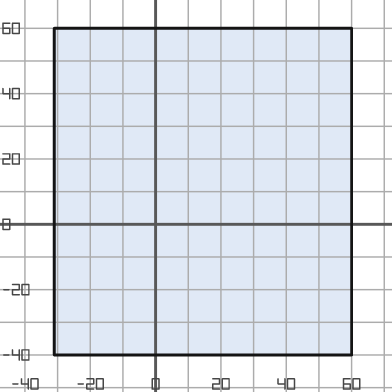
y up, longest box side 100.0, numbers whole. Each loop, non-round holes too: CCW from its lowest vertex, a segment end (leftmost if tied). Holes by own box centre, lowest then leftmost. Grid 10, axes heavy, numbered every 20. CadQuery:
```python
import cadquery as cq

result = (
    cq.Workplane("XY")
    .moveTo(-31.0, -40.0)
    .lineTo(60.0, -40.0)
    .lineTo(60.0, 60.0)
    .lineTo(-31.0, 60.0)
    .close()
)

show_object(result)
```